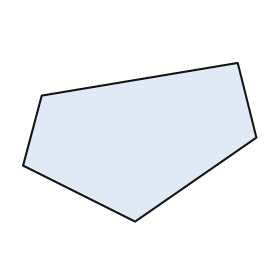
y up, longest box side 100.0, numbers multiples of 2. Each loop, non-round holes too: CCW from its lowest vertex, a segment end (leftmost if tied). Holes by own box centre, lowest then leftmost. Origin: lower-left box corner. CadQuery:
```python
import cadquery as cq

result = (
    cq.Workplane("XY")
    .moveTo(48.0, 0.0)
    .lineTo(100.0, 36.0)
    .lineTo(92.0, 68.0)
    .lineTo(8.0, 54.0)
    .lineTo(0.0, 24.0)
    .close()
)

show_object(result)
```